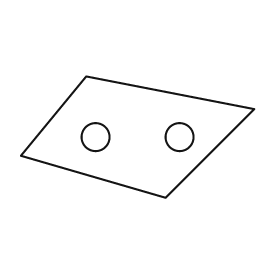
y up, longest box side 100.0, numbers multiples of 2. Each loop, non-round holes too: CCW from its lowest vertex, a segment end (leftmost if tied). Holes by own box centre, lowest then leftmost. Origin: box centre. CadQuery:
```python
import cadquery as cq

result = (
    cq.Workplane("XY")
    .moveTo(12.0, -26.0)
    .lineTo(50.0, 12.0)
    .lineTo(-22.0, 26.0)
    .lineTo(-50.0, -8.0)
    .close()
    .moveTo(-18.0, 0.0)
    .circle(6.0)
    .moveTo(18.0, 0.0)
    .circle(6.0)
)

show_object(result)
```